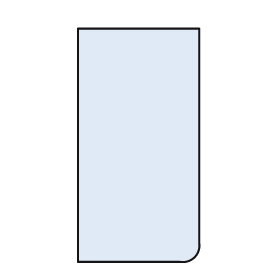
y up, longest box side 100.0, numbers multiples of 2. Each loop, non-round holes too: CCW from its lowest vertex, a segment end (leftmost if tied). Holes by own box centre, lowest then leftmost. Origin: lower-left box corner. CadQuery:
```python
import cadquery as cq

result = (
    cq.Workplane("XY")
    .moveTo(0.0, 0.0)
    .lineTo(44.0, 0.0)
    .threePointArc((50.0, 2.0), (52.0, 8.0))
    .lineTo(52.0, 100.0)
    .lineTo(0.0, 100.0)
    .close()
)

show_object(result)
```